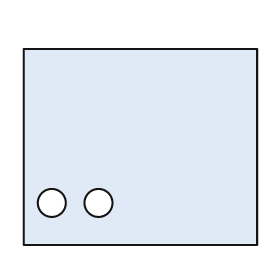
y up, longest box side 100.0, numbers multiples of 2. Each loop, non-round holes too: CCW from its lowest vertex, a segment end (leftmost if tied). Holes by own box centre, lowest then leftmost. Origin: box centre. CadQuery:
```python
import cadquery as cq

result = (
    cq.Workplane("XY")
    .moveTo(-50.0, -42.0)
    .lineTo(50.0, -42.0)
    .lineTo(50.0, 42.0)
    .lineTo(-50.0, 42.0)
    .close()
    .moveTo(-38.0, -24.0)
    .circle(6.0)
    .moveTo(-18.0, -24.0)
    .circle(6.0)
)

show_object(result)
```